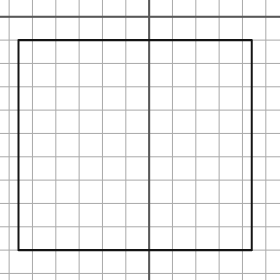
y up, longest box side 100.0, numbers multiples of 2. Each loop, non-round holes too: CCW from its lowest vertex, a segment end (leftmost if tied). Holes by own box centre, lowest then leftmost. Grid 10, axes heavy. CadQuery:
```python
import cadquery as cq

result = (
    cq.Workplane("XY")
    .moveTo(-56.0, -100.0)
    .lineTo(44.0, -100.0)
    .lineTo(44.0, -10.0)
    .lineTo(-56.0, -10.0)
    .close()
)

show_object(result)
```